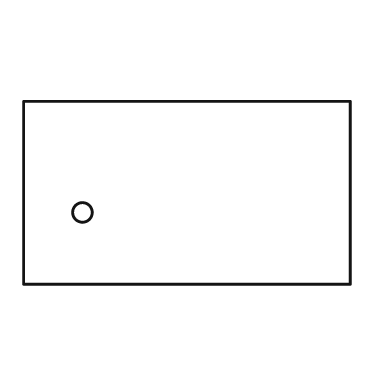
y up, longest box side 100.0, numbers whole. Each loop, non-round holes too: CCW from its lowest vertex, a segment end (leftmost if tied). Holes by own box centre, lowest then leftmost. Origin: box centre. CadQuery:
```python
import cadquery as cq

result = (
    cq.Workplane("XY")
    .moveTo(-50.0, -28.0)
    .lineTo(50.0, -28.0)
    .lineTo(50.0, 28.0)
    .lineTo(-50.0, 28.0)
    .close()
    .moveTo(-32.0, -6.0)
    .circle(3.0)
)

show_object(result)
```